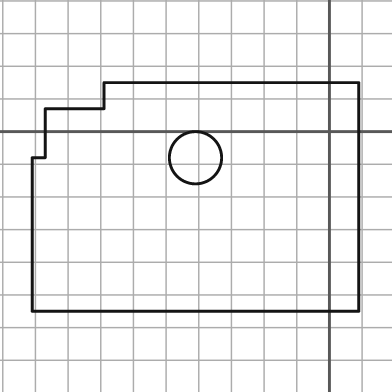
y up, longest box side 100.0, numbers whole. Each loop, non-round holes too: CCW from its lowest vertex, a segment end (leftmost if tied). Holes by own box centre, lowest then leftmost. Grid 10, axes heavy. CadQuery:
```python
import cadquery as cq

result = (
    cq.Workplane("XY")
    .moveTo(-91.0, -55.0)
    .lineTo(9.0, -55.0)
    .lineTo(9.0, 15.0)
    .lineTo(-69.0, 15.0)
    .lineTo(-69.0, 7.0)
    .lineTo(-87.0, 7.0)
    .lineTo(-87.0, -8.0)
    .lineTo(-91.0, -8.0)
    .close()
    .moveTo(-41.0, -8.0)
    .circle(8.0)
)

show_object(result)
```